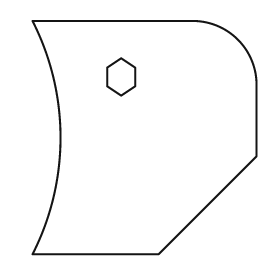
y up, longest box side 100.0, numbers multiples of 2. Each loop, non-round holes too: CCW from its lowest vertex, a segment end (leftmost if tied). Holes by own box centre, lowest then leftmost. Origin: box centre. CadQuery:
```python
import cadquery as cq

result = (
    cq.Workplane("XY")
    .moveTo(-48.0, -50.0)
    .lineTo(6.0, -50.0)
    .lineTo(48.0, -8.0)
    .lineTo(48.0, 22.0)
    .threePointArc((40.0, 42.0), (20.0, 50.0))
    .lineTo(-48.0, 50.0)
    .threePointArc((-36.0, 0.0), (-48.0, -50.0))
    .close()
    .moveTo(-10.0, 18.0)
    .lineTo(-4.0, 22.0)
    .lineTo(-4.0, 30.0)
    .lineTo(-10.0, 34.0)
    .lineTo(-16.0, 30.0)
    .lineTo(-16.0, 22.0)
    .close()
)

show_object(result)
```